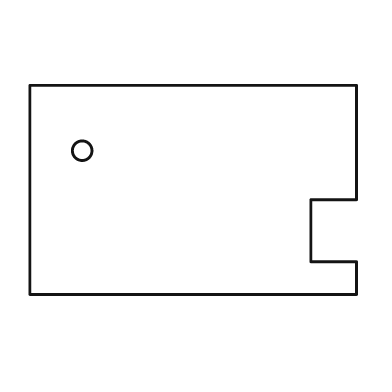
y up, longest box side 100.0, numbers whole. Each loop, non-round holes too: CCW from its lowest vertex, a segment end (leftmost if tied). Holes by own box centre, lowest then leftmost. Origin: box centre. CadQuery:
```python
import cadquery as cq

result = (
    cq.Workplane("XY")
    .moveTo(-50.0, -32.0)
    .lineTo(50.0, -32.0)
    .lineTo(50.0, -22.0)
    .lineTo(36.0, -22.0)
    .lineTo(36.0, -3.0)
    .lineTo(50.0, -3.0)
    .lineTo(50.0, 32.0)
    .lineTo(-50.0, 32.0)
    .close()
    .moveTo(-34.0, 12.0)
    .circle(3.0)
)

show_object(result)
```